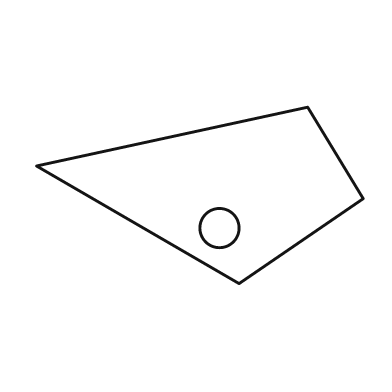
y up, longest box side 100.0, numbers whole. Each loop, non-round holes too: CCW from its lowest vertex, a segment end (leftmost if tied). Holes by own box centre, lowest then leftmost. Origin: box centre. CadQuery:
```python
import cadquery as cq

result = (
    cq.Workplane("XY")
    .moveTo(12.0, -27.0)
    .lineTo(50.0, -1.0)
    .lineTo(33.0, 27.0)
    .lineTo(-50.0, 9.0)
    .close()
    .moveTo(6.0, -10.0)
    .circle(6.0)
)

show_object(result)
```